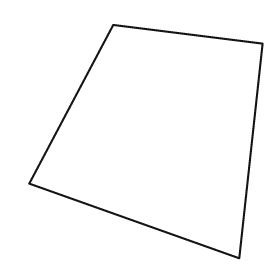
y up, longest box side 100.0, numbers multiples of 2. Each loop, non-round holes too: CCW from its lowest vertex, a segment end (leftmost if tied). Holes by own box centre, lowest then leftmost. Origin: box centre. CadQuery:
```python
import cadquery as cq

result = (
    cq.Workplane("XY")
    .moveTo(40.0, -50.0)
    .lineTo(50.0, 42.0)
    .lineTo(-14.0, 50.0)
    .lineTo(-50.0, -18.0)
    .close()
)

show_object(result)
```